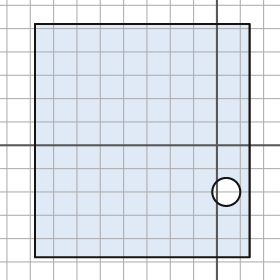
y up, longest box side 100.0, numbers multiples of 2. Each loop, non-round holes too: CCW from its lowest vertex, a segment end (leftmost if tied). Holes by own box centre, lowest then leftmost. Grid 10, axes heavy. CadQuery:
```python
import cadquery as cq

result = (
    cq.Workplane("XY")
    .moveTo(-78.0, -48.0)
    .lineTo(14.0, -48.0)
    .lineTo(14.0, 52.0)
    .lineTo(-78.0, 52.0)
    .close()
    .moveTo(4.0, -20.0)
    .circle(6.0)
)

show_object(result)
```